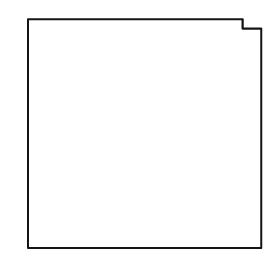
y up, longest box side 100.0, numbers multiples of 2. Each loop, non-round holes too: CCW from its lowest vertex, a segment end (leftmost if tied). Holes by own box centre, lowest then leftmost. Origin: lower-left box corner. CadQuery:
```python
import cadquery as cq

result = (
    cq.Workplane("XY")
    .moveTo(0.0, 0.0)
    .lineTo(100.0, 0.0)
    .lineTo(100.0, 94.0)
    .lineTo(92.0, 94.0)
    .lineTo(92.0, 98.0)
    .lineTo(0.0, 98.0)
    .close()
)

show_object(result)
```